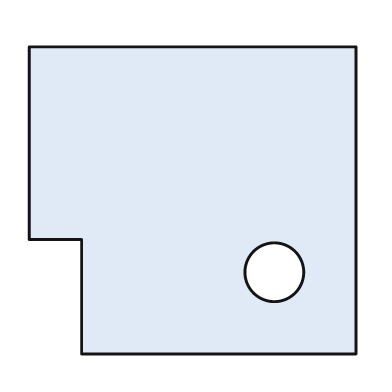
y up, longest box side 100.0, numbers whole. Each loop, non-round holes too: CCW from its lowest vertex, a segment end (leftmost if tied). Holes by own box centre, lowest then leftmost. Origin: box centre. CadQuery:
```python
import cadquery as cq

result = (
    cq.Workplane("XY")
    .moveTo(-34.0, -47.0)
    .lineTo(50.0, -47.0)
    .lineTo(50.0, 47.0)
    .lineTo(-50.0, 47.0)
    .lineTo(-50.0, -12.0)
    .lineTo(-34.0, -12.0)
    .close()
    .moveTo(25.0, -22.0)
    .circle(9.0)
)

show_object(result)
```